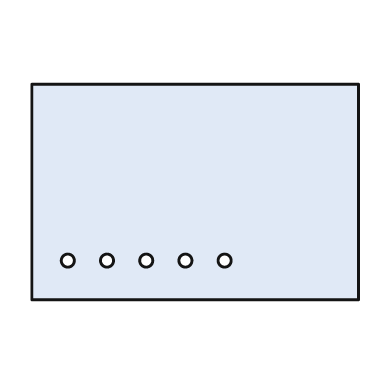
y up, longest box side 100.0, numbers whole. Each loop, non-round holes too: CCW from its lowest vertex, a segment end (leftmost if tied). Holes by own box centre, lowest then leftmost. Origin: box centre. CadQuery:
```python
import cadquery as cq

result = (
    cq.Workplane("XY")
    .moveTo(-50.0, -33.0)
    .lineTo(50.0, -33.0)
    .lineTo(50.0, 33.0)
    .lineTo(-50.0, 33.0)
    .close()
    .moveTo(-39.0, -21.0)
    .circle(2.0)
    .moveTo(-27.0, -21.0)
    .circle(2.0)
    .moveTo(-15.0, -21.0)
    .circle(2.0)
    .moveTo(-3.0, -21.0)
    .circle(2.0)
    .moveTo(9.0, -21.0)
    .circle(2.0)
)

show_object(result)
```